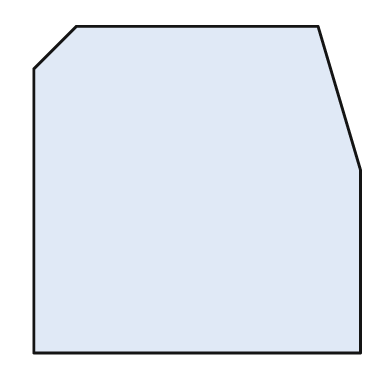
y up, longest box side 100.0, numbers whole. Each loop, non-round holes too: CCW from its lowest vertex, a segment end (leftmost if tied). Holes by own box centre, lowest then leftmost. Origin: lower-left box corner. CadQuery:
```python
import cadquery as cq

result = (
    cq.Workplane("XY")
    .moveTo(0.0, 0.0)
    .lineTo(100.0, 0.0)
    .lineTo(100.0, 56.0)
    .lineTo(87.0, 100.0)
    .lineTo(13.0, 100.0)
    .lineTo(0.0, 87.0)
    .close()
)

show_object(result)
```